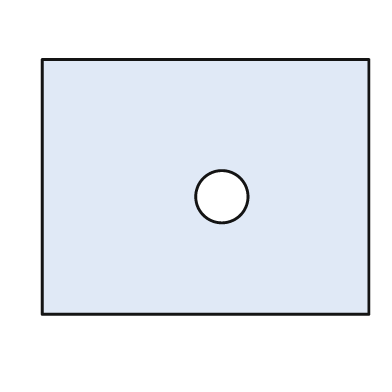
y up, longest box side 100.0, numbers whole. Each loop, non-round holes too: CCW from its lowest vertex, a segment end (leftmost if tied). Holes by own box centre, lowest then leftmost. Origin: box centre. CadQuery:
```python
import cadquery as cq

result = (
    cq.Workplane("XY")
    .moveTo(-50.0, -39.0)
    .lineTo(50.0, -39.0)
    .lineTo(50.0, 39.0)
    .lineTo(-50.0, 39.0)
    .close()
    .moveTo(5.0, -3.0)
    .circle(8.0)
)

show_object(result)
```